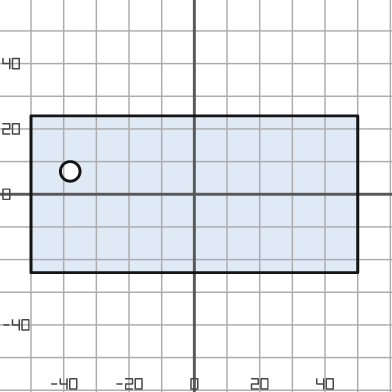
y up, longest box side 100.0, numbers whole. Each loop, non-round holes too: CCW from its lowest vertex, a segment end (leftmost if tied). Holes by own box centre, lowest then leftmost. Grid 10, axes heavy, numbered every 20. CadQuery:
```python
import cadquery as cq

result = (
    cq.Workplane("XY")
    .moveTo(-50.0, -24.0)
    .lineTo(50.0, -24.0)
    .lineTo(50.0, 24.0)
    .lineTo(-50.0, 24.0)
    .close()
    .moveTo(-38.0, 7.0)
    .circle(3.0)
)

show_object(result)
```